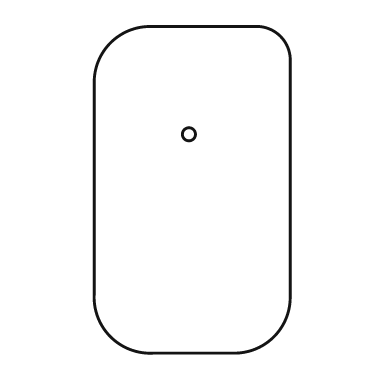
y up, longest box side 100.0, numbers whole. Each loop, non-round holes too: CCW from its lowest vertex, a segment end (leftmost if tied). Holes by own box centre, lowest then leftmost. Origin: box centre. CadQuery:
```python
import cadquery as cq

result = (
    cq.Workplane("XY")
    .moveTo(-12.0, -50.0)
    .lineTo(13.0, -50.0)
    .threePointArc((25.0, -45.0), (30.0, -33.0))
    .lineTo(30.0, 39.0)
    .threePointArc((27.0, 47.0), (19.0, 50.0))
    .lineTo(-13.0, 50.0)
    .threePointArc((-25.0, 45.0), (-30.0, 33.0))
    .lineTo(-30.0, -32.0)
    .threePointArc((-25.0, -45.0), (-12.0, -50.0))
    .close()
    .moveTo(-1.0, 17.0)
    .circle(2.0)
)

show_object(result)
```